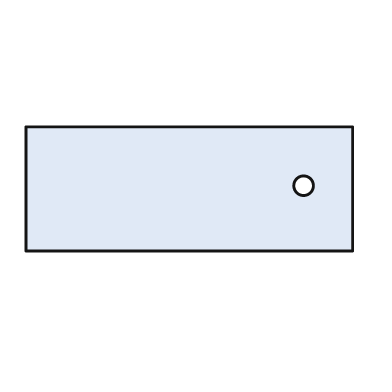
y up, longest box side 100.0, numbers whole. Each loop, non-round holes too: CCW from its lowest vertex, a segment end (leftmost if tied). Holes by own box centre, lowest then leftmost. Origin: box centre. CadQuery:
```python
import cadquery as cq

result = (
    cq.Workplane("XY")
    .moveTo(-50.0, -19.0)
    .lineTo(50.0, -19.0)
    .lineTo(50.0, 19.0)
    .lineTo(-50.0, 19.0)
    .close()
    .moveTo(35.0, 1.0)
    .circle(3.0)
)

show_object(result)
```